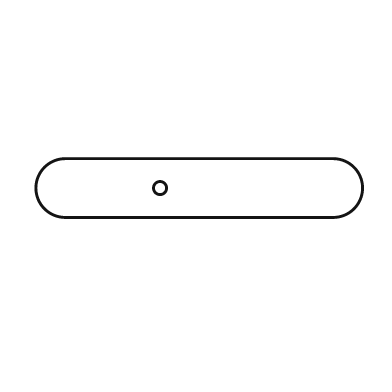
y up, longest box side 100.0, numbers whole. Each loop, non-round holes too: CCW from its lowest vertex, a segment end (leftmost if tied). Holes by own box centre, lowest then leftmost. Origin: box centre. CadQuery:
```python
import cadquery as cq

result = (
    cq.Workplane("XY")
    .moveTo(-41.0, -9.0)
    .lineTo(41.0, -9.0)
    .threePointArc((50.0, 0.0), (41.0, 9.0))
    .lineTo(-41.0, 9.0)
    .threePointArc((-50.0, 0.0), (-41.0, -9.0))
    .close()
    .moveTo(-12.0, 0.0)
    .circle(2.0)
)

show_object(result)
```